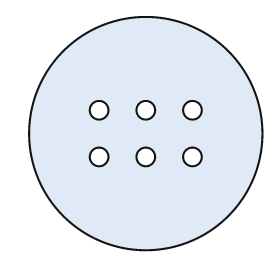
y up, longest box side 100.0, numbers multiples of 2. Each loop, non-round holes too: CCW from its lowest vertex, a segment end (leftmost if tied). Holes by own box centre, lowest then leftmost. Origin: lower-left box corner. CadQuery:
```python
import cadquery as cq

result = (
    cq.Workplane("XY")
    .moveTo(50.0, 50.0)
    .circle(50.0)
    .moveTo(30.0, 40.0)
    .circle(4.0)
    .moveTo(50.0, 40.0)
    .circle(4.0)
    .moveTo(70.0, 40.0)
    .circle(4.0)
    .moveTo(30.0, 60.0)
    .circle(4.0)
    .moveTo(50.0, 60.0)
    .circle(4.0)
    .moveTo(70.0, 60.0)
    .circle(4.0)
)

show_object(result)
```